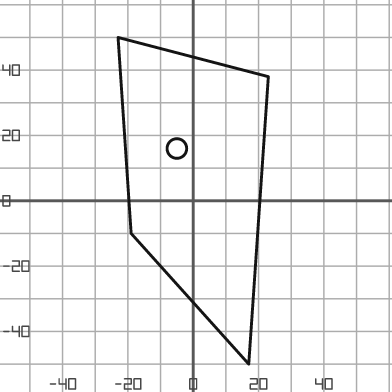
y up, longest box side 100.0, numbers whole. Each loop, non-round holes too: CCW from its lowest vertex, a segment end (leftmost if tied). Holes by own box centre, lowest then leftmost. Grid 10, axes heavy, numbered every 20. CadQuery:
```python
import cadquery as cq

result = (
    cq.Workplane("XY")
    .moveTo(17.0, -50.0)
    .lineTo(23.0, 38.0)
    .lineTo(-23.0, 50.0)
    .lineTo(-19.0, -10.0)
    .close()
    .moveTo(-5.0, 16.0)
    .circle(3.0)
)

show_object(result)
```